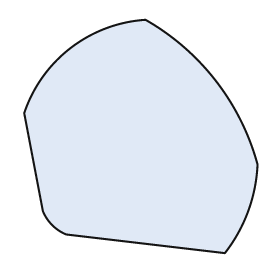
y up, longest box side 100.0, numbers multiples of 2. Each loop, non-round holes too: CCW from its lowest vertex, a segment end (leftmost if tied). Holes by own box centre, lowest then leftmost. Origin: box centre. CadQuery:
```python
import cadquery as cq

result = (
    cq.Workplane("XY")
    .moveTo(36.0, -50.0)
    .threePointArc((46.0, -32.0), (50.0, -12.0))
    .threePointArc((32.0, 24.0), (2.0, 50.0))
    .threePointArc((-30.0, 38.0), (-50.0, 10.0))
    .lineTo(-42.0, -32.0)
    .threePointArc((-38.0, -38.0), (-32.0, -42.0))
    .close()
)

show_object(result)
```